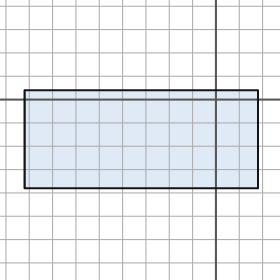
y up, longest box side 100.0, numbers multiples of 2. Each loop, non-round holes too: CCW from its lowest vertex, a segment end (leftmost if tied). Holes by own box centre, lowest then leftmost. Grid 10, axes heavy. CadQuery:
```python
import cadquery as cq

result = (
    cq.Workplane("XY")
    .moveTo(-82.0, -38.0)
    .lineTo(18.0, -38.0)
    .lineTo(18.0, 4.0)
    .lineTo(-82.0, 4.0)
    .close()
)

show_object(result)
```